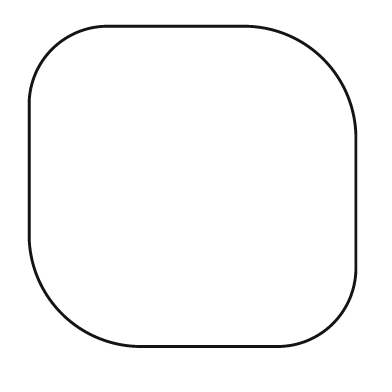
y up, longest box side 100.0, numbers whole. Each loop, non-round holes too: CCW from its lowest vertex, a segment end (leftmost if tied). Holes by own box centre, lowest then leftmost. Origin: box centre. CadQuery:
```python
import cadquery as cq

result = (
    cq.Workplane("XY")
    .moveTo(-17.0, -49.0)
    .lineTo(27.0, -49.0)
    .threePointArc((43.0, -42.0), (50.0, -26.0))
    .lineTo(50.0, 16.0)
    .threePointArc((40.0, 39.0), (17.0, 49.0))
    .lineTo(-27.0, 49.0)
    .threePointArc((-43.0, 42.0), (-50.0, 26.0))
    .lineTo(-50.0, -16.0)
    .threePointArc((-40.0, -39.0), (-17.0, -49.0))
    .close()
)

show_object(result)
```